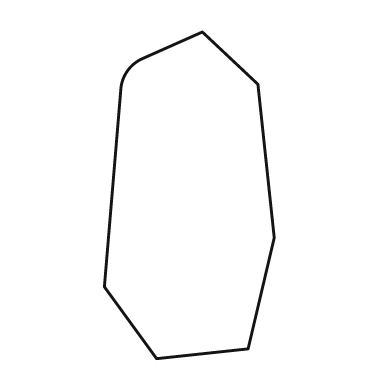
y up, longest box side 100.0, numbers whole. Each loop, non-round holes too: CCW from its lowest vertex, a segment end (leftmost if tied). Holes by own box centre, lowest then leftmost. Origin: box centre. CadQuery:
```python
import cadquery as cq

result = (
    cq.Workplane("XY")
    .moveTo(-10.0, -50.0)
    .lineTo(18.0, -47.0)
    .lineTo(26.0, -13.0)
    .lineTo(21.0, 34.0)
    .lineTo(4.0, 50.0)
    .lineTo(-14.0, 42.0)
    .threePointArc((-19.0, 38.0), (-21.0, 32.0))
    .lineTo(-26.0, -28.0)
    .close()
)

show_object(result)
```